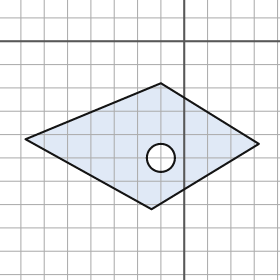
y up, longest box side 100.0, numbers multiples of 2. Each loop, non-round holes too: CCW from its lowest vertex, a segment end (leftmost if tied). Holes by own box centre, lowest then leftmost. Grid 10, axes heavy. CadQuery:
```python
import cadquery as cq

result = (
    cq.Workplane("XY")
    .moveTo(-14.0, -72.0)
    .lineTo(32.0, -44.0)
    .lineTo(-10.0, -18.0)
    .lineTo(-68.0, -42.0)
    .close()
    .moveTo(-10.0, -50.0)
    .circle(6.0)
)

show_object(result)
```